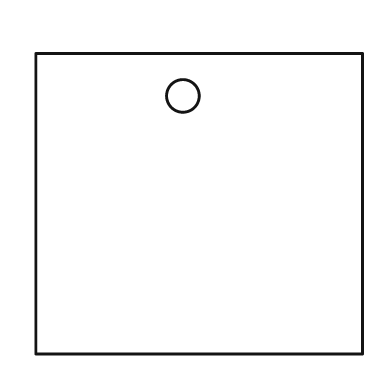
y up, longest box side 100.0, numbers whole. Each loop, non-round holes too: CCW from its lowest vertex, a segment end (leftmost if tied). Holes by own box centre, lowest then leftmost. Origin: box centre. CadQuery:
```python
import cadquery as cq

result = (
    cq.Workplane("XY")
    .moveTo(-50.0, -46.0)
    .lineTo(50.0, -46.0)
    .lineTo(50.0, 46.0)
    .lineTo(-50.0, 46.0)
    .close()
    .moveTo(-5.0, 33.0)
    .circle(5.0)
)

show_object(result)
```